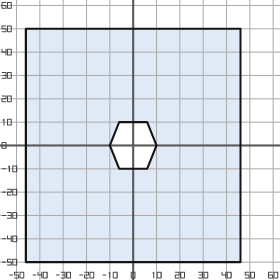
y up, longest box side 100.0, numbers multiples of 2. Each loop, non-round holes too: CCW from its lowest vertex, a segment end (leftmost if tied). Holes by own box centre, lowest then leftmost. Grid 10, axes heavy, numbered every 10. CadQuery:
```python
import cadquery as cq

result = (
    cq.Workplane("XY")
    .moveTo(-46.0, -50.0)
    .lineTo(46.0, -50.0)
    .lineTo(46.0, 50.0)
    .lineTo(-46.0, 50.0)
    .close()
    .moveTo(-6.0, -10.0)
    .lineTo(6.0, -10.0)
    .lineTo(10.0, 0.0)
    .lineTo(6.0, 10.0)
    .lineTo(-6.0, 10.0)
    .lineTo(-10.0, 0.0)
    .close()
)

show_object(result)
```